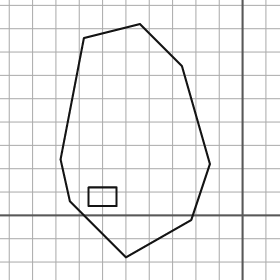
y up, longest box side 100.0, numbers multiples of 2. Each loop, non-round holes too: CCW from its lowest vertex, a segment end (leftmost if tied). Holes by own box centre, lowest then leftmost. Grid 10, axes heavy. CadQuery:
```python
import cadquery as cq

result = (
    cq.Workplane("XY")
    .moveTo(-50.0, -18.0)
    .lineTo(-22.0, -2.0)
    .lineTo(-14.0, 22.0)
    .lineTo(-26.0, 64.0)
    .lineTo(-44.0, 82.0)
    .lineTo(-68.0, 76.0)
    .lineTo(-78.0, 24.0)
    .lineTo(-74.0, 6.0)
    .close()
    .moveTo(-66.0, 4.0)
    .lineTo(-54.0, 4.0)
    .lineTo(-54.0, 12.0)
    .lineTo(-66.0, 12.0)
    .close()
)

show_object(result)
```